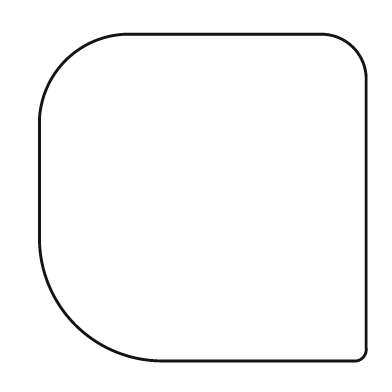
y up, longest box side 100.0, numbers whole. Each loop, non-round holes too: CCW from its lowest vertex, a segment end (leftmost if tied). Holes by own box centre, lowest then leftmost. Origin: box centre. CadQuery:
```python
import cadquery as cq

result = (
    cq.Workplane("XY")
    .moveTo(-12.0, -50.0)
    .lineTo(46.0, -50.0)
    .threePointArc((49.0, -49.0), (50.0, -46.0))
    .lineTo(50.0, 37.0)
    .threePointArc((46.0, 46.0), (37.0, 50.0))
    .lineTo(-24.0, 50.0)
    .threePointArc((-42.0, 42.0), (-50.0, 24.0))
    .lineTo(-50.0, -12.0)
    .threePointArc((-39.0, -39.0), (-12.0, -50.0))
    .close()
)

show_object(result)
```